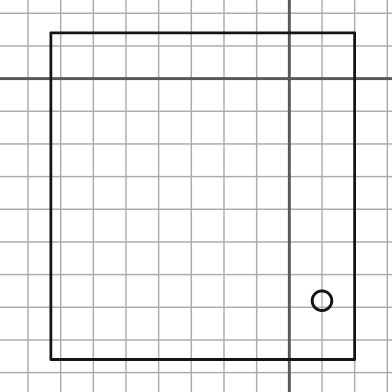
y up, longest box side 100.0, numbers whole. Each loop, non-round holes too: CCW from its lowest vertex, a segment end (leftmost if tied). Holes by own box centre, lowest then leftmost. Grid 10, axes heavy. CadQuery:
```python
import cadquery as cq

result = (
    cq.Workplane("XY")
    .moveTo(-73.0, -86.0)
    .lineTo(20.0, -86.0)
    .lineTo(20.0, 14.0)
    .lineTo(-73.0, 14.0)
    .close()
    .moveTo(10.0, -68.0)
    .circle(3.0)
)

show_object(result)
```